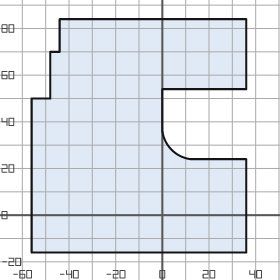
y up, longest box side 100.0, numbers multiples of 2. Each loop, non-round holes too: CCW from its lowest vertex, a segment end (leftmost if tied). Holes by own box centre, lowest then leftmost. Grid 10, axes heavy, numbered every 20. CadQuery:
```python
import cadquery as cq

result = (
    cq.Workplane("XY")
    .moveTo(-56.0, -16.0)
    .lineTo(36.0, -16.0)
    .lineTo(36.0, 24.0)
    .lineTo(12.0, 24.0)
    .threePointArc((4.0, 28.0), (0.0, 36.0))
    .lineTo(0.0, 54.0)
    .lineTo(36.0, 54.0)
    .lineTo(36.0, 84.0)
    .lineTo(-44.0, 84.0)
    .lineTo(-44.0, 70.0)
    .lineTo(-48.0, 70.0)
    .lineTo(-48.0, 50.0)
    .lineTo(-56.0, 50.0)
    .close()
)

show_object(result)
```